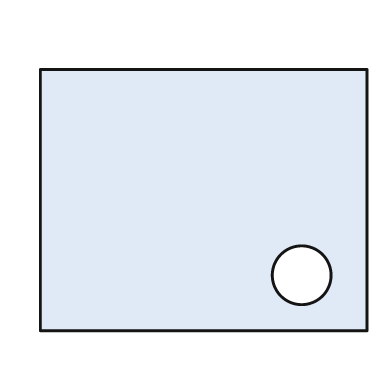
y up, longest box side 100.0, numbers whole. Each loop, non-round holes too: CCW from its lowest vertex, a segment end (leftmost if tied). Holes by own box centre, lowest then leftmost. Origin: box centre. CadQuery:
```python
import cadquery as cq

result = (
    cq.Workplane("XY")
    .moveTo(-50.0, -40.0)
    .lineTo(50.0, -40.0)
    .lineTo(50.0, 40.0)
    .lineTo(-50.0, 40.0)
    .close()
    .moveTo(30.0, -23.0)
    .circle(9.0)
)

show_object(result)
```